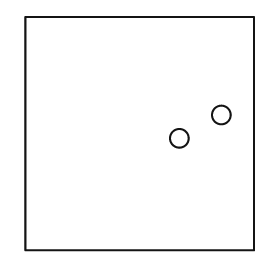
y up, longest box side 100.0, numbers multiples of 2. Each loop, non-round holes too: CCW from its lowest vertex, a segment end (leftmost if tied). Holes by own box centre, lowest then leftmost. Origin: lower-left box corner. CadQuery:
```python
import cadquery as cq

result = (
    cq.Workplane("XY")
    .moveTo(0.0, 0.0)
    .lineTo(98.0, 0.0)
    .lineTo(98.0, 100.0)
    .lineTo(0.0, 100.0)
    .close()
    .moveTo(66.0, 48.0)
    .circle(4.0)
    .moveTo(84.0, 58.0)
    .circle(4.0)
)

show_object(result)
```